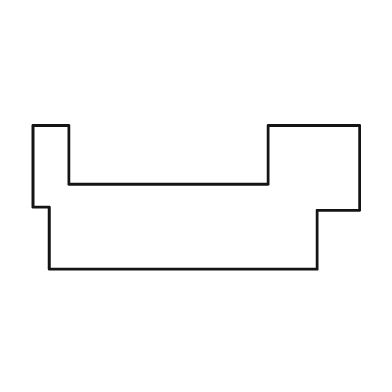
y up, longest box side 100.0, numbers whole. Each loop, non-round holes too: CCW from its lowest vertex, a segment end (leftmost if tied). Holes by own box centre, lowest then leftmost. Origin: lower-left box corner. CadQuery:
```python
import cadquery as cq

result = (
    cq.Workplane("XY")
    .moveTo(5.0, 0.0)
    .lineTo(87.0, 0.0)
    .lineTo(87.0, 18.0)
    .lineTo(100.0, 18.0)
    .lineTo(100.0, 44.0)
    .lineTo(72.0, 44.0)
    .lineTo(72.0, 26.0)
    .lineTo(11.0, 26.0)
    .lineTo(11.0, 44.0)
    .lineTo(0.0, 44.0)
    .lineTo(0.0, 19.0)
    .lineTo(5.0, 19.0)
    .close()
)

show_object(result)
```